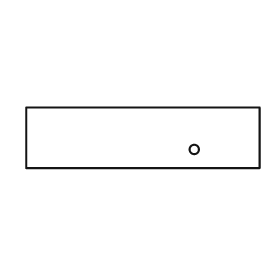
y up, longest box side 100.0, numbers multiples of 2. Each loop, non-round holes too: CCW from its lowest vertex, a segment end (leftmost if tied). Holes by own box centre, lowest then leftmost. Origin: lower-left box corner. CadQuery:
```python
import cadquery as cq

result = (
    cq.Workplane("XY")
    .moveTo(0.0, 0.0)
    .lineTo(100.0, 0.0)
    .lineTo(100.0, 26.0)
    .lineTo(0.0, 26.0)
    .close()
    .moveTo(72.0, 8.0)
    .circle(2.0)
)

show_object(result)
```